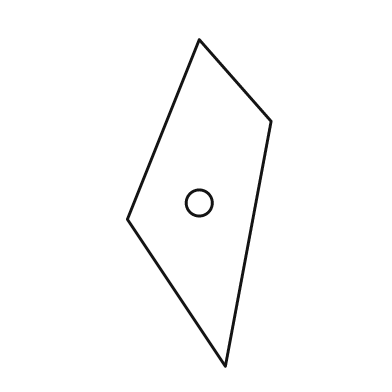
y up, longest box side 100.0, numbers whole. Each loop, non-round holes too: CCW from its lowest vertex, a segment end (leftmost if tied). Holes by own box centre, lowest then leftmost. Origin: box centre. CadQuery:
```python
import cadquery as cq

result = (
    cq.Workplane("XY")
    .moveTo(8.0, -50.0)
    .lineTo(22.0, 25.0)
    .lineTo(0.0, 50.0)
    .lineTo(-22.0, -5.0)
    .close()
    .moveTo(0.0, 0.0)
    .circle(4.0)
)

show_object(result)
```